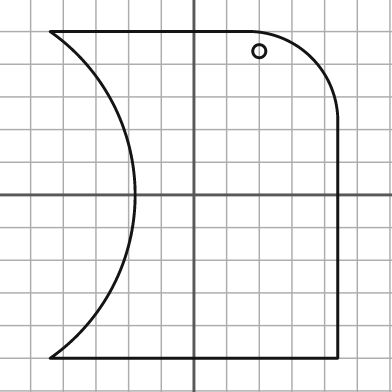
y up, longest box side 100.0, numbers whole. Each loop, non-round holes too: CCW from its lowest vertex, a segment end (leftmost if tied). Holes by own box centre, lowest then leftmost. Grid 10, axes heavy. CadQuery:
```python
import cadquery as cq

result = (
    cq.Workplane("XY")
    .moveTo(-44.0, -50.0)
    .lineTo(44.0, -50.0)
    .lineTo(44.0, 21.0)
    .threePointArc((36.0, 42.0), (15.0, 50.0))
    .lineTo(-44.0, 50.0)
    .threePointArc((-18.0, 0.0), (-44.0, -50.0))
    .close()
    .moveTo(20.0, 44.0)
    .circle(2.0)
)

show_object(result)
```